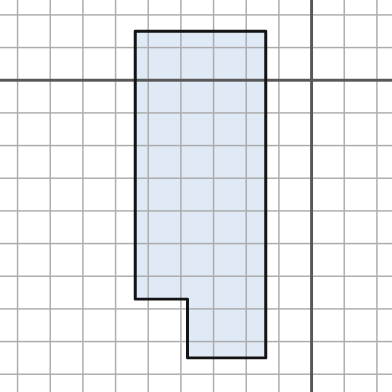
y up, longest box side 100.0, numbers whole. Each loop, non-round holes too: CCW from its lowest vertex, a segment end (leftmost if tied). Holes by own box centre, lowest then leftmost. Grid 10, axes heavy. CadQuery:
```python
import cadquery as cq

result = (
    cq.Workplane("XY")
    .moveTo(-38.0, -85.0)
    .lineTo(-14.0, -85.0)
    .lineTo(-14.0, 15.0)
    .lineTo(-54.0, 15.0)
    .lineTo(-54.0, -67.0)
    .lineTo(-38.0, -67.0)
    .close()
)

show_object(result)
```